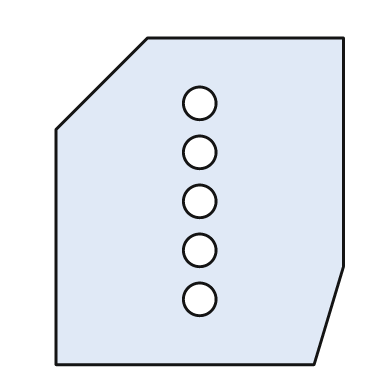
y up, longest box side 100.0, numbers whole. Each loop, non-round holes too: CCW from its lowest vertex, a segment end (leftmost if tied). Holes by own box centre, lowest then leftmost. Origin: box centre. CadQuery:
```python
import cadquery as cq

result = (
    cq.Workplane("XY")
    .moveTo(-44.0, -50.0)
    .lineTo(35.0, -50.0)
    .lineTo(44.0, -20.0)
    .lineTo(44.0, 50.0)
    .lineTo(-16.0, 50.0)
    .lineTo(-44.0, 22.0)
    .close()
    .moveTo(0.0, -30.0)
    .circle(5.0)
    .moveTo(0.0, -15.0)
    .circle(5.0)
    .moveTo(0.0, 0.0)
    .circle(5.0)
    .moveTo(0.0, 15.0)
    .circle(5.0)
    .moveTo(0.0, 30.0)
    .circle(5.0)
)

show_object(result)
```